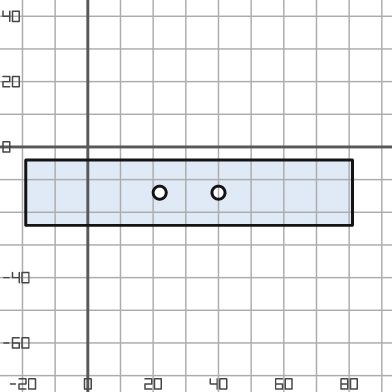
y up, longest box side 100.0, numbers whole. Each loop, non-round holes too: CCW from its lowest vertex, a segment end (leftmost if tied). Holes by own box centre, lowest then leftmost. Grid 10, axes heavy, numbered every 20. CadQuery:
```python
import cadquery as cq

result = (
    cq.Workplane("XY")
    .moveTo(-19.0, -24.0)
    .lineTo(81.0, -24.0)
    .lineTo(81.0, -4.0)
    .lineTo(-19.0, -4.0)
    .close()
    .moveTo(22.0, -14.0)
    .circle(2.0)
    .moveTo(40.0, -14.0)
    .circle(2.0)
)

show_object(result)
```